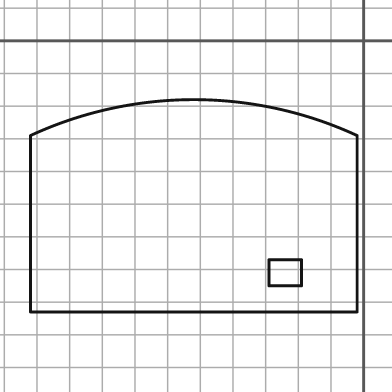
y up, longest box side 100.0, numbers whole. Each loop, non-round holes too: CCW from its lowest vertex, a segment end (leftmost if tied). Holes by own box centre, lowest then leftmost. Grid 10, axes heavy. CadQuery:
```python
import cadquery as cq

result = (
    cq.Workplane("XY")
    .moveTo(-102.0, -83.0)
    .lineTo(-2.0, -83.0)
    .lineTo(-2.0, -29.0)
    .threePointArc((-52.0, -18.0), (-102.0, -29.0))
    .close()
    .moveTo(-29.0, -75.0)
    .lineTo(-19.0, -75.0)
    .lineTo(-19.0, -67.0)
    .lineTo(-29.0, -67.0)
    .close()
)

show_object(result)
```